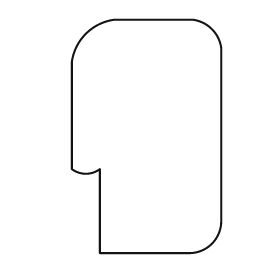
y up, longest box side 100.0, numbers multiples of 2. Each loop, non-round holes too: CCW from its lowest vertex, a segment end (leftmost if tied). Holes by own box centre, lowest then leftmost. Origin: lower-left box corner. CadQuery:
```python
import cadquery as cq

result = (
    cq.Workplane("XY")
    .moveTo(12.0, 0.0)
    .lineTo(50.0, 0.0)
    .threePointArc((60.0, 4.0), (64.0, 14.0))
    .lineTo(64.0, 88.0)
    .threePointArc((60.0, 96.0), (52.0, 100.0))
    .lineTo(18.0, 100.0)
    .threePointArc((6.0, 94.0), (0.0, 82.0))
    .lineTo(0.0, 36.0)
    .threePointArc((6.0, 34.0), (12.0, 36.0))
    .close()
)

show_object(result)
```